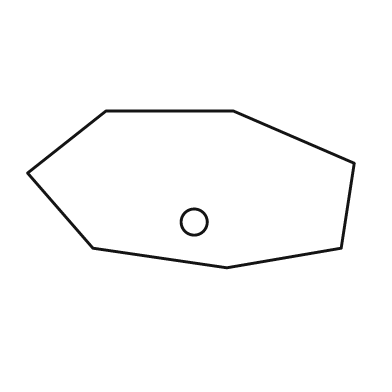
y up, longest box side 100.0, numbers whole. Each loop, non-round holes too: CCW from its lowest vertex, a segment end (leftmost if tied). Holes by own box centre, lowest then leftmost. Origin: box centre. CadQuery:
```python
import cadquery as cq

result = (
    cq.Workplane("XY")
    .moveTo(11.0, -24.0)
    .lineTo(46.0, -18.0)
    .lineTo(50.0, 8.0)
    .lineTo(13.0, 24.0)
    .lineTo(-26.0, 24.0)
    .lineTo(-50.0, 5.0)
    .lineTo(-30.0, -18.0)
    .close()
    .moveTo(1.0, -10.0)
    .circle(4.0)
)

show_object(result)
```